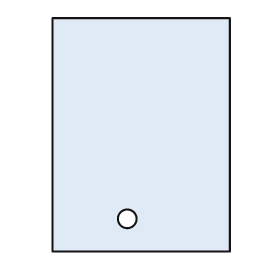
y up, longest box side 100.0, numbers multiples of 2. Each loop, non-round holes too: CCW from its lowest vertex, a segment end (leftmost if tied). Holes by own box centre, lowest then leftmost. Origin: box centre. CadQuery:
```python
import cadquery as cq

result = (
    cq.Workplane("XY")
    .moveTo(-38.0, -50.0)
    .lineTo(38.0, -50.0)
    .lineTo(38.0, 50.0)
    .lineTo(-38.0, 50.0)
    .close()
    .moveTo(-6.0, -36.0)
    .circle(4.0)
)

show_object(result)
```